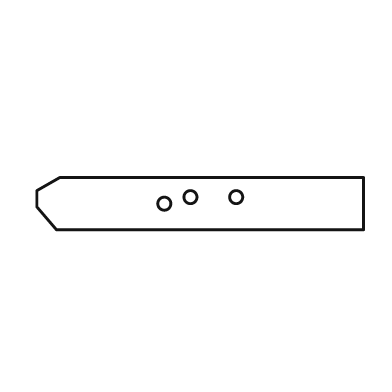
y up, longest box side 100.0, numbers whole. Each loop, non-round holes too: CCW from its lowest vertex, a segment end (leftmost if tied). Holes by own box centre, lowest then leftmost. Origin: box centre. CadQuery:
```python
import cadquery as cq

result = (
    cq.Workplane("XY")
    .moveTo(-44.0, -8.0)
    .lineTo(50.0, -8.0)
    .lineTo(50.0, 8.0)
    .lineTo(-43.0, 8.0)
    .lineTo(-50.0, 4.0)
    .lineTo(-50.0, -1.0)
    .close()
    .moveTo(-11.0, 0.0)
    .circle(2.0)
    .moveTo(-3.0, 2.0)
    .circle(2.0)
    .moveTo(11.0, 2.0)
    .circle(2.0)
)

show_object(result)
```